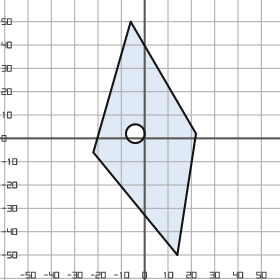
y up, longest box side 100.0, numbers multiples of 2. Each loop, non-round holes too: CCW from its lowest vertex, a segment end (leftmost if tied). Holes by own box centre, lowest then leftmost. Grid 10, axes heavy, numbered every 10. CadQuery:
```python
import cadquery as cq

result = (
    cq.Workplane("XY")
    .moveTo(14.0, -50.0)
    .lineTo(22.0, 2.0)
    .lineTo(-6.0, 50.0)
    .lineTo(-22.0, -6.0)
    .close()
    .moveTo(-4.0, 2.0)
    .circle(4.0)
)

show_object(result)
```